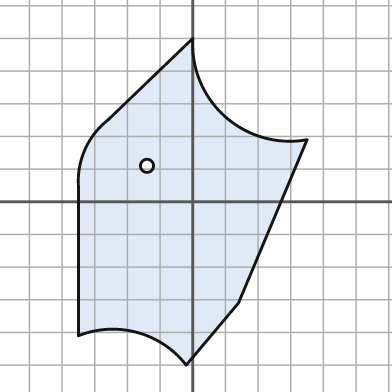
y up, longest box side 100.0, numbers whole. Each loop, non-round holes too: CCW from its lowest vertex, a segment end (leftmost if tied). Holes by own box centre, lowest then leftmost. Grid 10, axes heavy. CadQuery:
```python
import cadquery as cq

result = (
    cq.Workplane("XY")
    .moveTo(-2.0, -50.0)
    .lineTo(14.0, -31.0)
    .lineTo(35.0, 19.0)
    .threePointArc((10.0, 26.0), (0.0, 50.0))
    .lineTo(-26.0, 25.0)
    .threePointArc((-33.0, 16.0), (-35.0, 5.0))
    .lineTo(-35.0, -41.0)
    .threePointArc((-17.0, -40.0), (-2.0, -50.0))
    .close()
    .moveTo(-14.0, 11.0)
    .circle(2.0)
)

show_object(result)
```